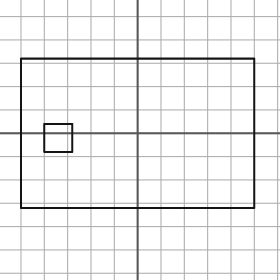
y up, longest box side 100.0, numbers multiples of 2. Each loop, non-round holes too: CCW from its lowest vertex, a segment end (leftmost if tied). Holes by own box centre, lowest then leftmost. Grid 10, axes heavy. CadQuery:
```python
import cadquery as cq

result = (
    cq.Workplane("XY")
    .moveTo(-50.0, -32.0)
    .lineTo(50.0, -32.0)
    .lineTo(50.0, 32.0)
    .lineTo(-50.0, 32.0)
    .close()
    .moveTo(-40.0, -8.0)
    .lineTo(-28.0, -8.0)
    .lineTo(-28.0, 4.0)
    .lineTo(-40.0, 4.0)
    .close()
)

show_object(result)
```